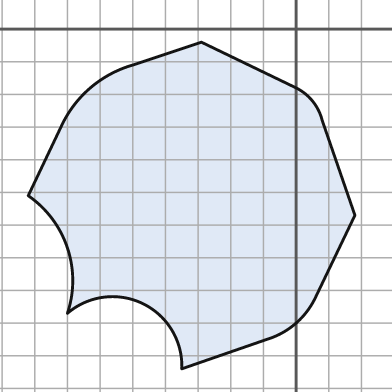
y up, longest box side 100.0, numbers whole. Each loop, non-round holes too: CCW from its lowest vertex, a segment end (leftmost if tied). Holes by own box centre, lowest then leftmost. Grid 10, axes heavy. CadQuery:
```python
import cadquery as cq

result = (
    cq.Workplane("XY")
    .moveTo(-35.0, -104.0)
    .lineTo(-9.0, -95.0)
    .threePointArc((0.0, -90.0), (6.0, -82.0))
    .lineTo(18.0, -57.0)
    .lineTo(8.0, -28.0)
    .threePointArc((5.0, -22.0), (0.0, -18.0))
    .lineTo(-29.0, -4.0)
    .lineTo(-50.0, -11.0)
    .threePointArc((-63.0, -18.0), (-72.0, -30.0))
    .lineTo(-82.0, -51.0)
    .threePointArc((-70.0, -67.0), (-70.0, -87.0))
    .threePointArc((-47.0, -84.0), (-35.0, -104.0))
    .close()
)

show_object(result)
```